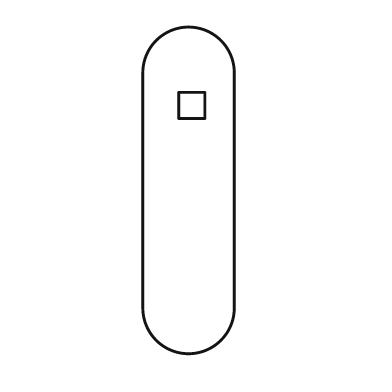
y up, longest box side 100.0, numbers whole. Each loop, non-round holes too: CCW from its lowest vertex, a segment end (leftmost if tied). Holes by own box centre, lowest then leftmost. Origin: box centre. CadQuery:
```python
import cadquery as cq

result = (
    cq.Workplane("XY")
    .moveTo(-14.0, -36.0)
    .threePointArc((0.0, -50.0), (14.0, -36.0))
    .lineTo(14.0, 36.0)
    .threePointArc((0.0, 50.0), (-14.0, 36.0))
    .close()
    .moveTo(-3.0, 22.0)
    .lineTo(5.0, 22.0)
    .lineTo(5.0, 30.0)
    .lineTo(-3.0, 30.0)
    .close()
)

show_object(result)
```